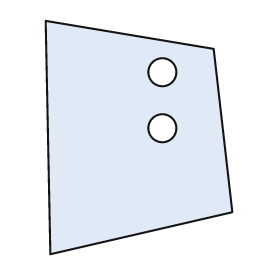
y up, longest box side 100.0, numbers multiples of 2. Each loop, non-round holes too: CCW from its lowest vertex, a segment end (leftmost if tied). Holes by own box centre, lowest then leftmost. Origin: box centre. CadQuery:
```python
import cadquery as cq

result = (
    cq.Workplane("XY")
    .moveTo(-38.0, -50.0)
    .lineTo(40.0, -32.0)
    .lineTo(32.0, 38.0)
    .lineTo(-40.0, 50.0)
    .close()
    .moveTo(10.0, 4.0)
    .circle(6.0)
    .moveTo(10.0, 28.0)
    .circle(6.0)
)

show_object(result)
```